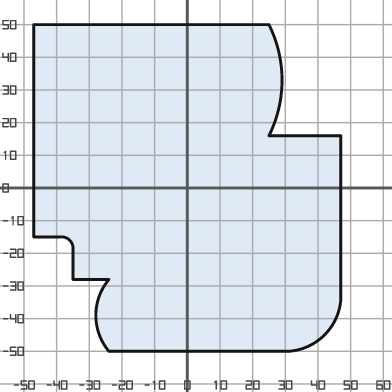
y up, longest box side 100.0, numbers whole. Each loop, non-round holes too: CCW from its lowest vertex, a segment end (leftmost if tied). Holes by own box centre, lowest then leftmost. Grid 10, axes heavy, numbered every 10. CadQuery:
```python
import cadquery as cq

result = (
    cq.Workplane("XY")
    .moveTo(-24.0, -50.0)
    .lineTo(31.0, -50.0)
    .threePointArc((42.0, -45.0), (47.0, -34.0))
    .lineTo(47.0, 16.0)
    .lineTo(25.0, 16.0)
    .threePointArc((29.0, 33.0), (25.0, 50.0))
    .lineTo(-47.0, 50.0)
    .lineTo(-47.0, -15.0)
    .lineTo(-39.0, -15.0)
    .threePointArc((-36.0, -16.0), (-35.0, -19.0))
    .lineTo(-35.0, -28.0)
    .lineTo(-24.0, -28.0)
    .threePointArc((-28.0, -39.0), (-24.0, -50.0))
    .close()
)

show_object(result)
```